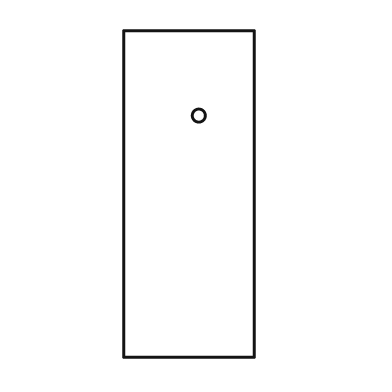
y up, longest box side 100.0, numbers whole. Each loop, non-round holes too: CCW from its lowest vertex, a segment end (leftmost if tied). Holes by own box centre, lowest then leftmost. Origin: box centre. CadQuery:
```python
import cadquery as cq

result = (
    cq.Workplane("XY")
    .moveTo(-20.0, -50.0)
    .lineTo(20.0, -50.0)
    .lineTo(20.0, 50.0)
    .lineTo(-20.0, 50.0)
    .close()
    .moveTo(3.0, 24.0)
    .circle(2.0)
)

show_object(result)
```